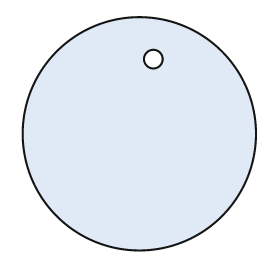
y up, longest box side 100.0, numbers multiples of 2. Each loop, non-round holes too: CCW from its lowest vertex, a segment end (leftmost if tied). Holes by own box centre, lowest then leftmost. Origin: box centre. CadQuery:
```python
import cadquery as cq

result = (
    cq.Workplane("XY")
    .moveTo(0.0, 0.0)
    .circle(50.0)
    .moveTo(6.0, 32.0)
    .circle(4.0)
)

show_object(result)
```